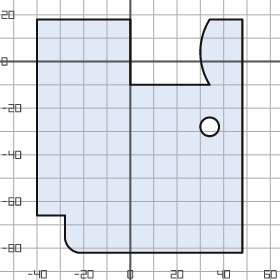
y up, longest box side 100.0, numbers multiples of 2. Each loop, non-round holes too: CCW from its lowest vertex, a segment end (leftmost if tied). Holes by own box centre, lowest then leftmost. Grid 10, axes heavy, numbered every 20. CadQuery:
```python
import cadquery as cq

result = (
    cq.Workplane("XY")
    .moveTo(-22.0, -82.0)
    .lineTo(48.0, -82.0)
    .lineTo(48.0, 18.0)
    .lineTo(34.0, 18.0)
    .threePointArc((30.0, 4.0), (34.0, -10.0))
    .lineTo(0.0, -10.0)
    .lineTo(0.0, 18.0)
    .lineTo(-40.0, 18.0)
    .lineTo(-40.0, -66.0)
    .lineTo(-28.0, -66.0)
    .lineTo(-28.0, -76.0)
    .threePointArc((-26.0, -80.0), (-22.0, -82.0))
    .close()
    .moveTo(34.0, -28.0)
    .circle(4.0)
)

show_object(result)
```